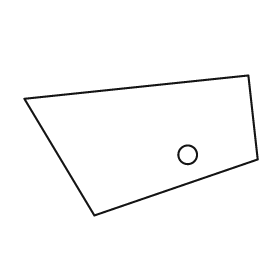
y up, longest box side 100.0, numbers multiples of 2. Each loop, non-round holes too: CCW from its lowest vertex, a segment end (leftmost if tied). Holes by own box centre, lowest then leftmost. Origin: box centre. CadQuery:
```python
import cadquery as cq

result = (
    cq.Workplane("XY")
    .moveTo(-20.0, -30.0)
    .lineTo(50.0, -6.0)
    .lineTo(46.0, 30.0)
    .lineTo(-50.0, 20.0)
    .close()
    .moveTo(20.0, -4.0)
    .circle(4.0)
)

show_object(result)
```